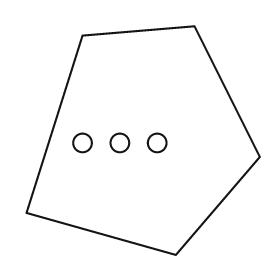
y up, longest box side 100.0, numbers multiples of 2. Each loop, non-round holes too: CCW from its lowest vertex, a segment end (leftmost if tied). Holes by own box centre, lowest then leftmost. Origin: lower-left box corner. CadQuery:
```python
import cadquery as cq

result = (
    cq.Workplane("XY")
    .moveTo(64.0, 0.0)
    .lineTo(100.0, 42.0)
    .lineTo(72.0, 98.0)
    .lineTo(24.0, 94.0)
    .lineTo(0.0, 18.0)
    .close()
    .moveTo(24.0, 48.0)
    .circle(4.0)
    .moveTo(40.0, 48.0)
    .circle(4.0)
    .moveTo(56.0, 48.0)
    .circle(4.0)
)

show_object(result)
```